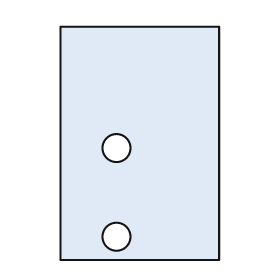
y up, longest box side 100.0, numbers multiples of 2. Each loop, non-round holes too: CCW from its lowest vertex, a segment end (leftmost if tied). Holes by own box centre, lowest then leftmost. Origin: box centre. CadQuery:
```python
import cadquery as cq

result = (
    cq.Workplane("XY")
    .moveTo(-34.0, -50.0)
    .lineTo(34.0, -50.0)
    .lineTo(34.0, 50.0)
    .lineTo(-34.0, 50.0)
    .close()
    .moveTo(-10.0, -40.0)
    .circle(6.0)
    .moveTo(-10.0, -2.0)
    .circle(6.0)
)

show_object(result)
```